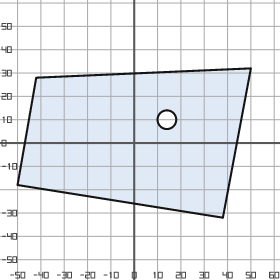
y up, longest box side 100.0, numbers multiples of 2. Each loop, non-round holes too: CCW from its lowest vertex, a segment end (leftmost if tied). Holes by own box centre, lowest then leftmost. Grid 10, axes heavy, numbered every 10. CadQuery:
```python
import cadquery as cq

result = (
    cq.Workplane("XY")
    .moveTo(38.0, -32.0)
    .lineTo(50.0, 32.0)
    .lineTo(-42.0, 28.0)
    .lineTo(-50.0, -18.0)
    .close()
    .moveTo(14.0, 10.0)
    .circle(4.0)
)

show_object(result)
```